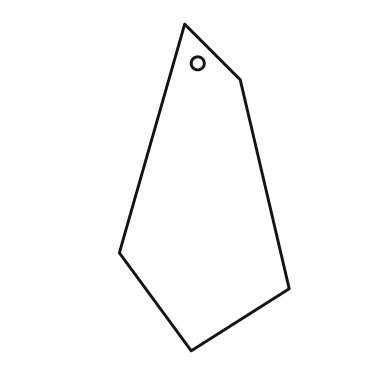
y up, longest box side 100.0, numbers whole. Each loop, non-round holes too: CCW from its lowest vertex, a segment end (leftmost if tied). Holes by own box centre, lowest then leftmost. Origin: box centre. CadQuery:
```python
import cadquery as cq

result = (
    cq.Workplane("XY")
    .moveTo(-4.0, -50.0)
    .lineTo(26.0, -31.0)
    .lineTo(11.0, 33.0)
    .lineTo(-6.0, 50.0)
    .lineTo(-26.0, -20.0)
    .close()
    .moveTo(-2.0, 38.0)
    .circle(2.0)
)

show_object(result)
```